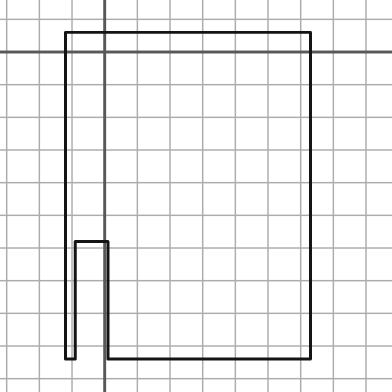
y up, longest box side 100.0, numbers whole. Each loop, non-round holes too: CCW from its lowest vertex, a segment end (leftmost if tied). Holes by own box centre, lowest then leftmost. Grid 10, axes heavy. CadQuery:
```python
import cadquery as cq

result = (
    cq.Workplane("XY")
    .moveTo(-12.0, -94.0)
    .lineTo(-9.0, -94.0)
    .lineTo(-9.0, -58.0)
    .lineTo(1.0, -58.0)
    .lineTo(1.0, -94.0)
    .lineTo(63.0, -94.0)
    .lineTo(63.0, 6.0)
    .lineTo(-12.0, 6.0)
    .close()
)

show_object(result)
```